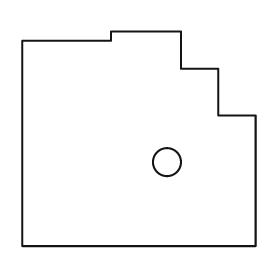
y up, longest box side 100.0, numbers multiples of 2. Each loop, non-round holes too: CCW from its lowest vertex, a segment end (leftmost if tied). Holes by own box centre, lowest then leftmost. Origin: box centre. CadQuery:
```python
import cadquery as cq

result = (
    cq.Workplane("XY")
    .moveTo(-50.0, -46.0)
    .lineTo(50.0, -46.0)
    .lineTo(50.0, 10.0)
    .lineTo(34.0, 10.0)
    .lineTo(34.0, 30.0)
    .lineTo(18.0, 30.0)
    .lineTo(18.0, 46.0)
    .lineTo(-12.0, 46.0)
    .lineTo(-12.0, 42.0)
    .lineTo(-50.0, 42.0)
    .close()
    .moveTo(12.0, -10.0)
    .circle(6.0)
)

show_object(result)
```